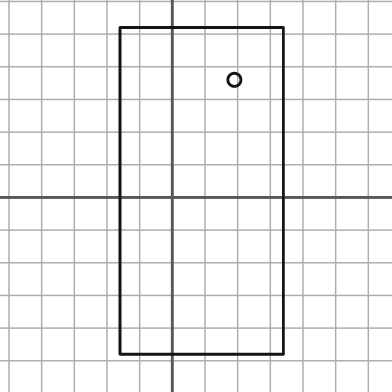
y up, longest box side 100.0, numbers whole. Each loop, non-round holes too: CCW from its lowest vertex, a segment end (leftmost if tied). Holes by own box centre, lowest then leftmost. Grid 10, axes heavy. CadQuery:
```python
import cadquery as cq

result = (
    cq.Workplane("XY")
    .moveTo(-16.0, -48.0)
    .lineTo(34.0, -48.0)
    .lineTo(34.0, 52.0)
    .lineTo(-16.0, 52.0)
    .close()
    .moveTo(19.0, 36.0)
    .circle(2.0)
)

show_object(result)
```